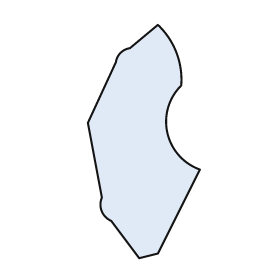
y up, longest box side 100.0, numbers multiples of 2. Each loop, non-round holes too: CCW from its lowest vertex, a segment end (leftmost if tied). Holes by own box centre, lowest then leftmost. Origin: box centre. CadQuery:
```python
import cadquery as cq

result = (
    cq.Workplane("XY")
    .moveTo(-2.0, -50.0)
    .lineTo(6.0, -48.0)
    .lineTo(24.0, -12.0)
    .threePointArc((10.0, 4.0), (16.0, 24.0))
    .threePointArc((14.0, 38.0), (6.0, 50.0))
    .lineTo(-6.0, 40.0)
    .threePointArc((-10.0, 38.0), (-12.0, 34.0))
    .lineTo(-24.0, 8.0)
    .lineTo(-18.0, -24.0)
    .threePointArc((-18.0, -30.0), (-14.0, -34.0))
    .close()
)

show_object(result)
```